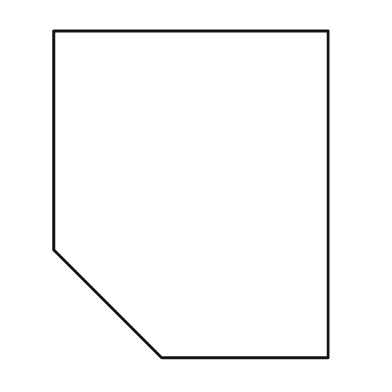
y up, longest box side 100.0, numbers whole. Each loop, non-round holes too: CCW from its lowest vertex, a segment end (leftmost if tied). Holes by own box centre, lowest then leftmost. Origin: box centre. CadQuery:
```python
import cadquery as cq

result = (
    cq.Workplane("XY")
    .moveTo(-9.0, -50.0)
    .lineTo(42.0, -50.0)
    .lineTo(42.0, 50.0)
    .lineTo(-42.0, 50.0)
    .lineTo(-42.0, -17.0)
    .close()
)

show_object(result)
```